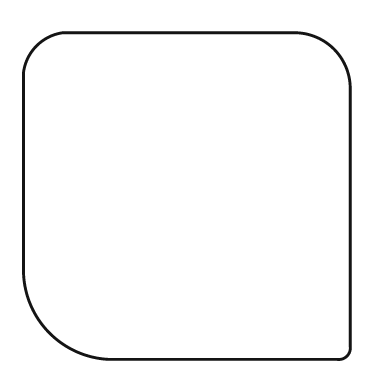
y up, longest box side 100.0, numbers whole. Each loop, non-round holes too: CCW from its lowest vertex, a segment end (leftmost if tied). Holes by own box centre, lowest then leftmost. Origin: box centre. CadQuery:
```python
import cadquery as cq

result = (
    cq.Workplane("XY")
    .moveTo(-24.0, -50.0)
    .lineTo(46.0, -50.0)
    .threePointArc((49.0, -49.0), (50.0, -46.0))
    .lineTo(50.0, 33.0)
    .threePointArc((45.0, 45.0), (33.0, 50.0))
    .lineTo(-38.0, 50.0)
    .threePointArc((-46.0, 46.0), (-50.0, 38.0))
    .lineTo(-50.0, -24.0)
    .threePointArc((-42.0, -42.0), (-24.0, -50.0))
    .close()
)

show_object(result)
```